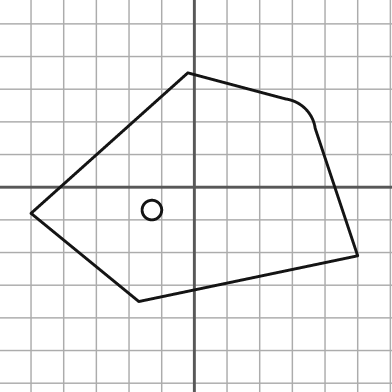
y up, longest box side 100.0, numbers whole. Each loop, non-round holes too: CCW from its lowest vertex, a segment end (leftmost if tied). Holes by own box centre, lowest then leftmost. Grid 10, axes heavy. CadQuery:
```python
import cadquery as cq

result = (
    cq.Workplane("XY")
    .moveTo(-17.0, -35.0)
    .lineTo(50.0, -21.0)
    .lineTo(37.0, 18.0)
    .threePointArc((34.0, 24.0), (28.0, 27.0))
    .lineTo(-2.0, 35.0)
    .lineTo(-50.0, -8.0)
    .close()
    .moveTo(-13.0, -7.0)
    .circle(3.0)
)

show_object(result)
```